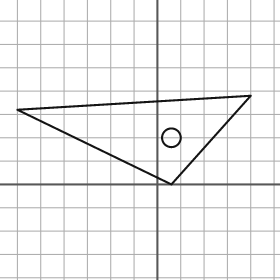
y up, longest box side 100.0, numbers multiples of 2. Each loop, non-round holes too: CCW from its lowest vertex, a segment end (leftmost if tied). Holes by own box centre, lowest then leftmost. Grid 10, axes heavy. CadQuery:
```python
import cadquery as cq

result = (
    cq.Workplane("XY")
    .moveTo(6.0, 0.0)
    .lineTo(40.0, 38.0)
    .lineTo(-60.0, 32.0)
    .close()
    .moveTo(6.0, 20.0)
    .circle(4.0)
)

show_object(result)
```